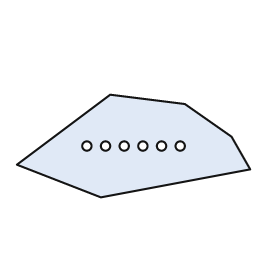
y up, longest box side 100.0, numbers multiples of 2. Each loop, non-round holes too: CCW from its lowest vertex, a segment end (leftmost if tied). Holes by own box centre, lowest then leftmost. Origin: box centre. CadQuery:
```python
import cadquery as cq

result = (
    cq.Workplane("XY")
    .moveTo(-14.0, -22.0)
    .lineTo(50.0, -10.0)
    .lineTo(42.0, 4.0)
    .lineTo(22.0, 18.0)
    .lineTo(-10.0, 22.0)
    .lineTo(-50.0, -8.0)
    .close()
    .moveTo(-20.0, 0.0)
    .circle(2.0)
    .moveTo(-12.0, 0.0)
    .circle(2.0)
    .moveTo(-4.0, 0.0)
    .circle(2.0)
    .moveTo(4.0, 0.0)
    .circle(2.0)
    .moveTo(12.0, 0.0)
    .circle(2.0)
    .moveTo(20.0, 0.0)
    .circle(2.0)
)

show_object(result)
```